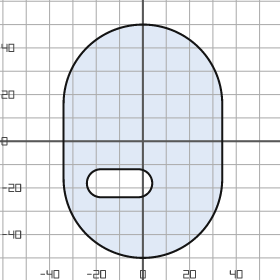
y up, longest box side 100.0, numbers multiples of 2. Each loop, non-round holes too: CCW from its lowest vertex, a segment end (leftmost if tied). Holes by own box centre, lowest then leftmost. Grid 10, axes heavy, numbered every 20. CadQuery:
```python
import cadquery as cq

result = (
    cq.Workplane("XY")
    .moveTo(-34.0, -16.0)
    .threePointArc((0.0, -50.0), (34.0, -16.0))
    .lineTo(34.0, 16.0)
    .threePointArc((0.0, 50.0), (-34.0, 16.0))
    .close()
    .moveTo(-18.0, -24.0)
    .lineTo(-2.0, -24.0)
    .threePointArc((4.0, -18.0), (-2.0, -12.0))
    .lineTo(-18.0, -12.0)
    .threePointArc((-24.0, -18.0), (-18.0, -24.0))
    .close()
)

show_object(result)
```